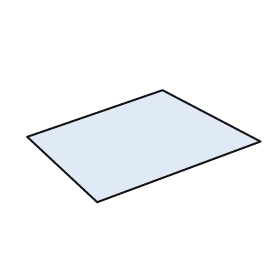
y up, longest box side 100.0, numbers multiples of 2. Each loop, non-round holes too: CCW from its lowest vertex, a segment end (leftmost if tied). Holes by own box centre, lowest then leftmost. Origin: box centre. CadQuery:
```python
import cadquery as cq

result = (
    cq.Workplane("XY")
    .moveTo(-20.0, -24.0)
    .lineTo(50.0, 2.0)
    .lineTo(8.0, 24.0)
    .lineTo(-50.0, 4.0)
    .close()
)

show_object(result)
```